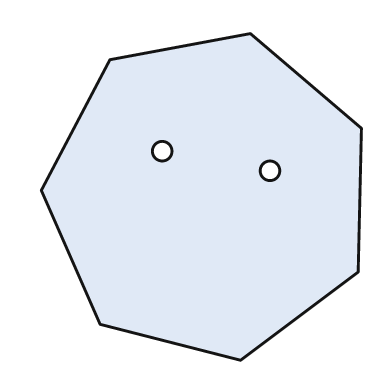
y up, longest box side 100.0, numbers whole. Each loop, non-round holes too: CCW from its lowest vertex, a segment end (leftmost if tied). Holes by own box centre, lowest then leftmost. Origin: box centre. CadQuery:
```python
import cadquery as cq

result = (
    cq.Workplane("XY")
    .moveTo(12.0, -50.0)
    .lineTo(48.0, -23.0)
    .lineTo(49.0, 21.0)
    .lineTo(15.0, 50.0)
    .lineTo(-28.0, 42.0)
    .lineTo(-49.0, 2.0)
    .lineTo(-31.0, -39.0)
    .close()
    .moveTo(21.0, 8.0)
    .circle(3.0)
    .moveTo(-12.0, 14.0)
    .circle(3.0)
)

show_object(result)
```